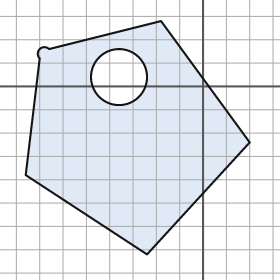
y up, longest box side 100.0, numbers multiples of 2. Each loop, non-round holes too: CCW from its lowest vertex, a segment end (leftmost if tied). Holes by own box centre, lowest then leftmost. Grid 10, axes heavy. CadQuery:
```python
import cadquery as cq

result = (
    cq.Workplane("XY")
    .moveTo(-24.0, -72.0)
    .lineTo(20.0, -24.0)
    .lineTo(-18.0, 28.0)
    .lineTo(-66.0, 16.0)
    .threePointArc((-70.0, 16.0), (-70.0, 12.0))
    .lineTo(-76.0, -38.0)
    .close()
    .moveTo(-36.0, 4.0)
    .circle(12.0)
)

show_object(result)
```